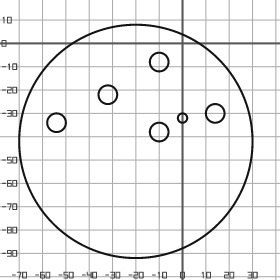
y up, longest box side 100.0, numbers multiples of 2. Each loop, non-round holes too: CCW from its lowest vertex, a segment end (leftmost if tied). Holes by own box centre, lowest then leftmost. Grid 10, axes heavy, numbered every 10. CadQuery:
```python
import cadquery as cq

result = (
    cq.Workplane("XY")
    .moveTo(-20.0, -42.0)
    .circle(50.0)
    .moveTo(-10.0, -38.0)
    .circle(4.0)
    .moveTo(-54.0, -34.0)
    .circle(4.0)
    .moveTo(0.0, -32.0)
    .circle(2.0)
    .moveTo(14.0, -30.0)
    .circle(4.0)
    .moveTo(-32.0, -22.0)
    .circle(4.0)
    .moveTo(-10.0, -8.0)
    .circle(4.0)
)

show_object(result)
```